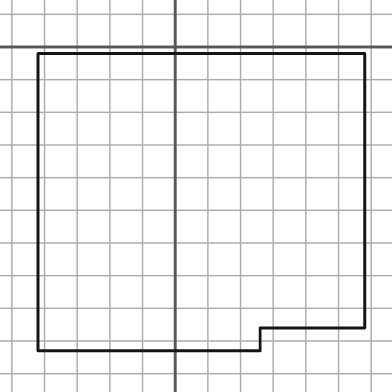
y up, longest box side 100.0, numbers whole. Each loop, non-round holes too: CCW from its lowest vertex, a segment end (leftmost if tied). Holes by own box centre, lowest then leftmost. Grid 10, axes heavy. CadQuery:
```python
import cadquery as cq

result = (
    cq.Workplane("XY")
    .moveTo(-42.0, -93.0)
    .lineTo(26.0, -93.0)
    .lineTo(26.0, -86.0)
    .lineTo(58.0, -86.0)
    .lineTo(58.0, -2.0)
    .lineTo(-42.0, -2.0)
    .close()
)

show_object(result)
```